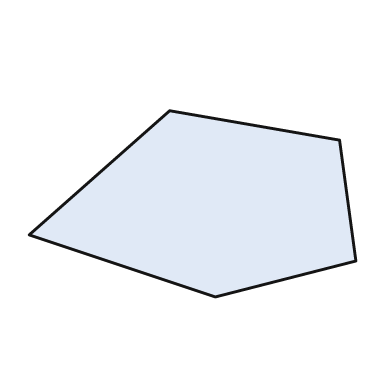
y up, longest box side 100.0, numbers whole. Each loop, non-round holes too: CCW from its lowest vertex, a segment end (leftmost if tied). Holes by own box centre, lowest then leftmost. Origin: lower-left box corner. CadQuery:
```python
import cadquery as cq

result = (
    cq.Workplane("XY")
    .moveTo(57.0, 0.0)
    .lineTo(100.0, 11.0)
    .lineTo(95.0, 48.0)
    .lineTo(43.0, 57.0)
    .lineTo(0.0, 19.0)
    .close()
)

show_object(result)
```